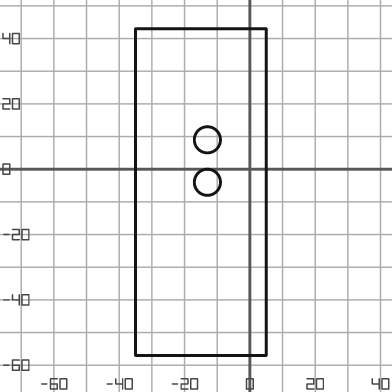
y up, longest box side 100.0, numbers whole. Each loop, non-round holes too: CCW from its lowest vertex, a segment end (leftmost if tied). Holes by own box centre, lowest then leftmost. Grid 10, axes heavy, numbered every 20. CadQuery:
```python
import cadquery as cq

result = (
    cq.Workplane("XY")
    .moveTo(-35.0, -57.0)
    .lineTo(5.0, -57.0)
    .lineTo(5.0, 43.0)
    .lineTo(-35.0, 43.0)
    .close()
    .moveTo(-13.0, -4.0)
    .circle(4.0)
    .moveTo(-13.0, 9.0)
    .circle(4.0)
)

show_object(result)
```